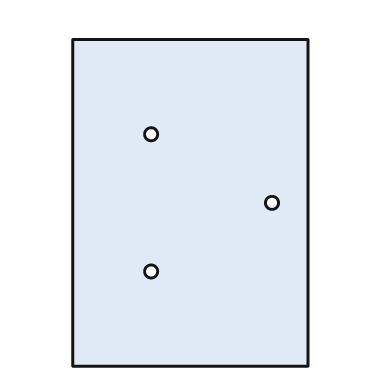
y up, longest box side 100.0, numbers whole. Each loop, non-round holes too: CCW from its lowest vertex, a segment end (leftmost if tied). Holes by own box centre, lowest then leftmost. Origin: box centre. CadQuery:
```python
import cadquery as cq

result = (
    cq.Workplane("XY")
    .moveTo(-36.0, -50.0)
    .lineTo(36.0, -50.0)
    .lineTo(36.0, 50.0)
    .lineTo(-36.0, 50.0)
    .close()
    .moveTo(-12.0, -21.0)
    .circle(2.0)
    .moveTo(25.0, 0.0)
    .circle(2.0)
    .moveTo(-12.0, 21.0)
    .circle(2.0)
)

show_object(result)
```